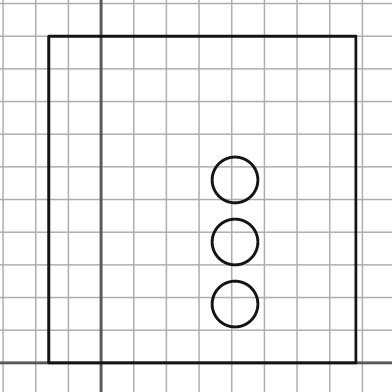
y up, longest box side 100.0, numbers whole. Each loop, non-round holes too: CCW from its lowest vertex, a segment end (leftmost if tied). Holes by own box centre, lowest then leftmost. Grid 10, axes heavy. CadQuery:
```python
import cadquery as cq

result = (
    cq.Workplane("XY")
    .moveTo(-16.0, 0.0)
    .lineTo(78.0, 0.0)
    .lineTo(78.0, 100.0)
    .lineTo(-16.0, 100.0)
    .close()
    .moveTo(41.0, 18.0)
    .circle(7.0)
    .moveTo(41.0, 37.0)
    .circle(7.0)
    .moveTo(41.0, 56.0)
    .circle(7.0)
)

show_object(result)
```